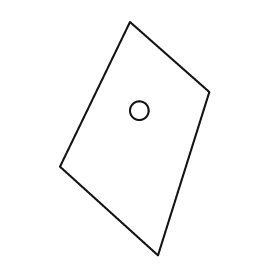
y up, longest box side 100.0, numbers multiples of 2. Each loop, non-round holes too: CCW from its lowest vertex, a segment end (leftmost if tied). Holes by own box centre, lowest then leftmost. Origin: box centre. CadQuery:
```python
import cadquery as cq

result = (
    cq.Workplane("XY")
    .moveTo(10.0, -50.0)
    .lineTo(32.0, 20.0)
    .lineTo(-2.0, 50.0)
    .lineTo(-32.0, -12.0)
    .close()
    .moveTo(2.0, 12.0)
    .circle(4.0)
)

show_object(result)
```